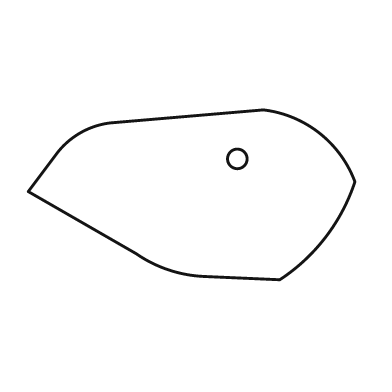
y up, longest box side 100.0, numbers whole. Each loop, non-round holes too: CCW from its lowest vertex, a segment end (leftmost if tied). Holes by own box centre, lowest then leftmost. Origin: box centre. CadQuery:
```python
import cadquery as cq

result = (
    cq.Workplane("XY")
    .moveTo(27.0, -26.0)
    .threePointArc((41.0, -13.0), (50.0, 4.0))
    .threePointArc((39.0, 19.0), (22.0, 26.0))
    .lineTo(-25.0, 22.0)
    .threePointArc((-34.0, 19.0), (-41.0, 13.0))
    .lineTo(-50.0, 1.0)
    .lineTo(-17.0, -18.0)
    .threePointArc((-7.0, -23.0), (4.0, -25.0))
    .close()
    .moveTo(14.0, 11.0)
    .circle(3.0)
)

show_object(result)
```